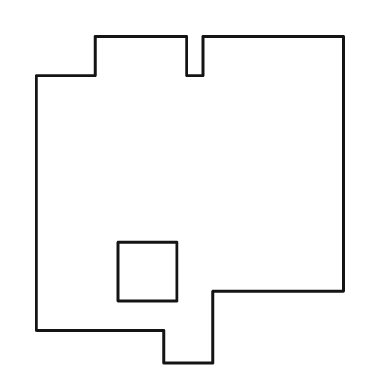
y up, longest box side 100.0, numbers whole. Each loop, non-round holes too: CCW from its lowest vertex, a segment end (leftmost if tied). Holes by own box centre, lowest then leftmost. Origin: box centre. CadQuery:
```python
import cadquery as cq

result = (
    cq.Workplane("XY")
    .moveTo(-8.0, -50.0)
    .lineTo(7.0, -50.0)
    .lineTo(7.0, -28.0)
    .lineTo(47.0, -28.0)
    .lineTo(47.0, 50.0)
    .lineTo(4.0, 50.0)
    .lineTo(4.0, 38.0)
    .lineTo(-1.0, 38.0)
    .lineTo(-1.0, 50.0)
    .lineTo(-29.0, 50.0)
    .lineTo(-29.0, 38.0)
    .lineTo(-47.0, 38.0)
    .lineTo(-47.0, -40.0)
    .lineTo(-8.0, -40.0)
    .close()
    .moveTo(-22.0, -31.0)
    .lineTo(-4.0, -31.0)
    .lineTo(-4.0, -13.0)
    .lineTo(-22.0, -13.0)
    .close()
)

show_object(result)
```